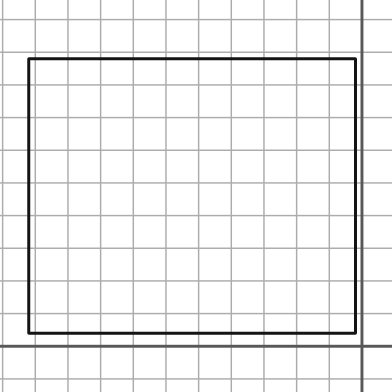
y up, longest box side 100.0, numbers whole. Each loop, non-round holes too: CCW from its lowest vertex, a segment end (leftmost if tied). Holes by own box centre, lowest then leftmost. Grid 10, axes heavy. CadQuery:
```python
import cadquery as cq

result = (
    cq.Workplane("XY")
    .moveTo(-102.0, 4.0)
    .lineTo(-2.0, 4.0)
    .lineTo(-2.0, 88.0)
    .lineTo(-102.0, 88.0)
    .close()
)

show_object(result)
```